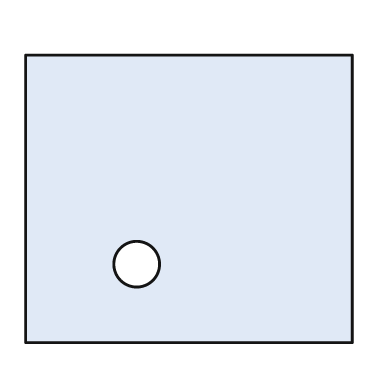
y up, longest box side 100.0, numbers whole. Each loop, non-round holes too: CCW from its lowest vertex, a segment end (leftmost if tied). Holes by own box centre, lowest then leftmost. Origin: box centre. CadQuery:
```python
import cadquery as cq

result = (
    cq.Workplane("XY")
    .moveTo(-50.0, -44.0)
    .lineTo(50.0, -44.0)
    .lineTo(50.0, 44.0)
    .lineTo(-50.0, 44.0)
    .close()
    .moveTo(-16.0, -20.0)
    .circle(7.0)
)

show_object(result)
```